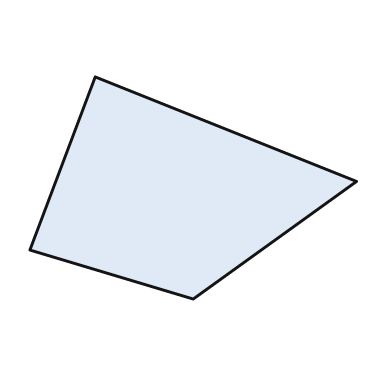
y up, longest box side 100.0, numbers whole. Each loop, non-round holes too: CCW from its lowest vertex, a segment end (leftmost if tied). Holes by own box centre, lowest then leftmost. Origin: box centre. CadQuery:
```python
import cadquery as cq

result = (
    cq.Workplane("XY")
    .moveTo(0.0, -34.0)
    .lineTo(50.0, 2.0)
    .lineTo(-30.0, 34.0)
    .lineTo(-50.0, -19.0)
    .close()
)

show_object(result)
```